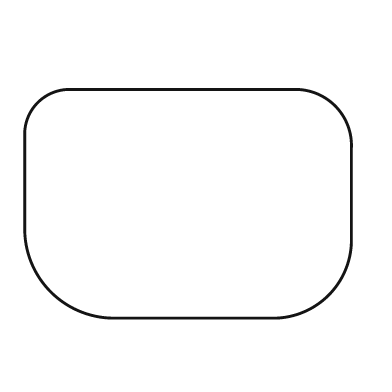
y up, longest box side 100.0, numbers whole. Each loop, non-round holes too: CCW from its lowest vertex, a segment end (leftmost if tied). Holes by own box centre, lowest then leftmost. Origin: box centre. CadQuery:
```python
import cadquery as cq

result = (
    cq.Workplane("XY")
    .moveTo(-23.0, -35.0)
    .lineTo(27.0, -35.0)
    .threePointArc((43.0, -28.0), (50.0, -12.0))
    .lineTo(50.0, 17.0)
    .threePointArc((45.0, 30.0), (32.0, 35.0))
    .lineTo(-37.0, 35.0)
    .threePointArc((-46.0, 31.0), (-50.0, 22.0))
    .lineTo(-50.0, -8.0)
    .threePointArc((-42.0, -27.0), (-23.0, -35.0))
    .close()
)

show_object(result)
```